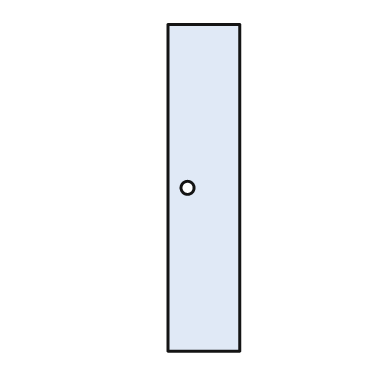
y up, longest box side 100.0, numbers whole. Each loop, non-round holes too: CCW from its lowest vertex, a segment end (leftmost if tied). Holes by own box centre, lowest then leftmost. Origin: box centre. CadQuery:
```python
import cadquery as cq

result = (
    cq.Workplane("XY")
    .moveTo(-11.0, -50.0)
    .lineTo(11.0, -50.0)
    .lineTo(11.0, 50.0)
    .lineTo(-11.0, 50.0)
    .close()
    .moveTo(-5.0, 0.0)
    .circle(2.0)
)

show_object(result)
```